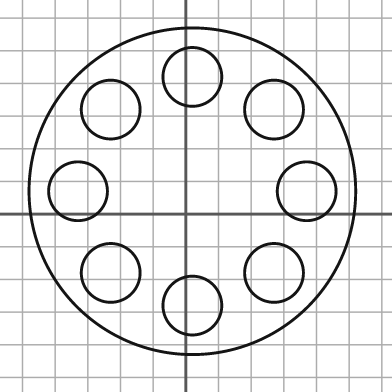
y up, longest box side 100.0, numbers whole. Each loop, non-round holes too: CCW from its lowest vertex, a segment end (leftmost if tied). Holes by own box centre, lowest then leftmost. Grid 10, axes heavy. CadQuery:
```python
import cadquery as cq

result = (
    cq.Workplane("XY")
    .moveTo(2.0, 7.0)
    .circle(50.0)
    .moveTo(2.0, -28.0)
    .circle(9.0)
    .moveTo(-23.0, -18.0)
    .circle(9.0)
    .moveTo(27.0, -18.0)
    .circle(9.0)
    .moveTo(-33.0, 7.0)
    .circle(9.0)
    .moveTo(37.0, 7.0)
    .circle(9.0)
    .moveTo(-23.0, 32.0)
    .circle(9.0)
    .moveTo(27.0, 32.0)
    .circle(9.0)
    .moveTo(2.0, 42.0)
    .circle(9.0)
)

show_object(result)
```